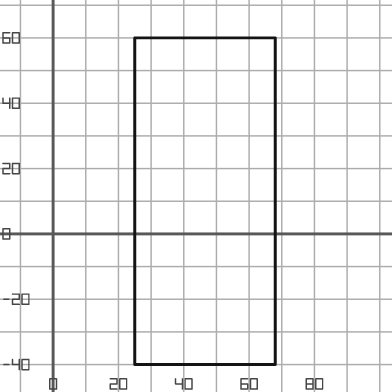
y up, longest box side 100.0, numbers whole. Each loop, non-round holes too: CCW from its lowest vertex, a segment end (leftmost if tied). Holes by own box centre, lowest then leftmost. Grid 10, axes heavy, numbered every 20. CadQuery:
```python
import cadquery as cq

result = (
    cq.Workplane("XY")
    .moveTo(25.0, -40.0)
    .lineTo(68.0, -40.0)
    .lineTo(68.0, 60.0)
    .lineTo(25.0, 60.0)
    .close()
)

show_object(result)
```